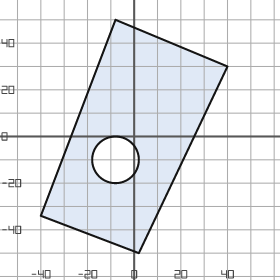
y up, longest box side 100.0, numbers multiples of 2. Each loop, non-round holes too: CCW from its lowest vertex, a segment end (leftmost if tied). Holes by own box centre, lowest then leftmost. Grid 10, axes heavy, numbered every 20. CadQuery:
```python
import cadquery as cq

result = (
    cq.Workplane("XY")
    .moveTo(2.0, -50.0)
    .lineTo(40.0, 30.0)
    .lineTo(-8.0, 50.0)
    .lineTo(-40.0, -34.0)
    .close()
    .moveTo(-8.0, -10.0)
    .circle(10.0)
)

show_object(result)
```